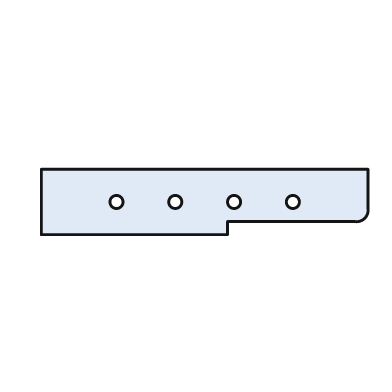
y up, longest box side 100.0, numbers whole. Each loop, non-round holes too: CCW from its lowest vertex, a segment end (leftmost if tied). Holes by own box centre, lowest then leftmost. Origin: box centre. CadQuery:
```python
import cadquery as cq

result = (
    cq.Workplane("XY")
    .moveTo(-50.0, -10.0)
    .lineTo(7.0, -10.0)
    .lineTo(7.0, -6.0)
    .lineTo(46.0, -6.0)
    .threePointArc((49.0, -5.0), (50.0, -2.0))
    .lineTo(50.0, 10.0)
    .lineTo(-50.0, 10.0)
    .close()
    .moveTo(-27.0, 0.0)
    .circle(2.0)
    .moveTo(-9.0, 0.0)
    .circle(2.0)
    .moveTo(9.0, 0.0)
    .circle(2.0)
    .moveTo(27.0, 0.0)
    .circle(2.0)
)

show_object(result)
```